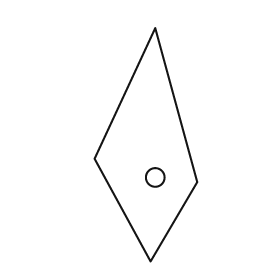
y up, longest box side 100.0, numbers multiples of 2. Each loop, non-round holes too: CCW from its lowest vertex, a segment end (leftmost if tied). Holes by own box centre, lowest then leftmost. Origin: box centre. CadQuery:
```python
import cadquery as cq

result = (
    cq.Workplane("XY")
    .moveTo(2.0, -50.0)
    .lineTo(22.0, -16.0)
    .lineTo(4.0, 50.0)
    .lineTo(-22.0, -6.0)
    .close()
    .moveTo(4.0, -14.0)
    .circle(4.0)
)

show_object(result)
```